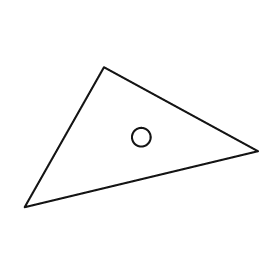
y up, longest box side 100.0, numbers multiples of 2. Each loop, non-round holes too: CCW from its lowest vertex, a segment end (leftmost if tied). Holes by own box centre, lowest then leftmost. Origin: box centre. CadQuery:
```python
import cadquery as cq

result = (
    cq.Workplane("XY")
    .moveTo(-50.0, -30.0)
    .lineTo(50.0, -6.0)
    .lineTo(-16.0, 30.0)
    .close()
    .moveTo(0.0, 0.0)
    .circle(4.0)
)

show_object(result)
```